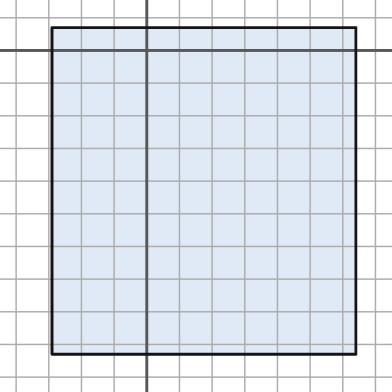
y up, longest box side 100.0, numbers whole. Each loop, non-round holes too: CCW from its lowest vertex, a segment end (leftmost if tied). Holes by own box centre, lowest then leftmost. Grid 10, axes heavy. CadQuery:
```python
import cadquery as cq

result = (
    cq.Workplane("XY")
    .moveTo(-29.0, -93.0)
    .lineTo(64.0, -93.0)
    .lineTo(64.0, 7.0)
    .lineTo(-29.0, 7.0)
    .close()
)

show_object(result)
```